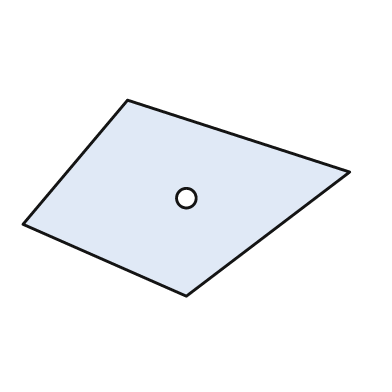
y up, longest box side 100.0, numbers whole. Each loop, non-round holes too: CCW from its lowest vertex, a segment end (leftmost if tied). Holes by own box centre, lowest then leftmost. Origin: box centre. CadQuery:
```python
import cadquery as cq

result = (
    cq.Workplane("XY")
    .moveTo(0.0, -30.0)
    .lineTo(50.0, 8.0)
    .lineTo(-18.0, 30.0)
    .lineTo(-50.0, -8.0)
    .close()
    .moveTo(0.0, 0.0)
    .circle(3.0)
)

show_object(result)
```